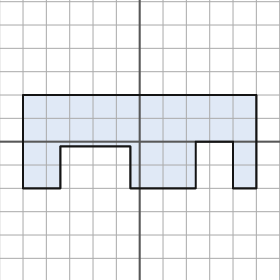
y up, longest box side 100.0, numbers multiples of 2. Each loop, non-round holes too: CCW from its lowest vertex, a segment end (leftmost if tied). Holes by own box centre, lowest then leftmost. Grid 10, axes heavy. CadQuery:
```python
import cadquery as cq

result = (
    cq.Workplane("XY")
    .moveTo(-50.0, -20.0)
    .lineTo(-34.0, -20.0)
    .lineTo(-34.0, -2.0)
    .lineTo(-4.0, -2.0)
    .lineTo(-4.0, -20.0)
    .lineTo(24.0, -20.0)
    .lineTo(24.0, 0.0)
    .lineTo(40.0, 0.0)
    .lineTo(40.0, -20.0)
    .lineTo(50.0, -20.0)
    .lineTo(50.0, 20.0)
    .lineTo(-50.0, 20.0)
    .close()
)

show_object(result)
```